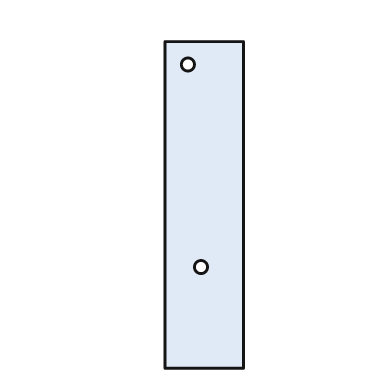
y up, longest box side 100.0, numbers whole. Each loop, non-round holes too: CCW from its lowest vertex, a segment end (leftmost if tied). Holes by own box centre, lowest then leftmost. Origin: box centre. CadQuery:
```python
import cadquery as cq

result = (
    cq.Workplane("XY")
    .moveTo(-12.0, -50.0)
    .lineTo(12.0, -50.0)
    .lineTo(12.0, 50.0)
    .lineTo(-12.0, 50.0)
    .close()
    .moveTo(-1.0, -19.0)
    .circle(2.0)
    .moveTo(-5.0, 43.0)
    .circle(2.0)
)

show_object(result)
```